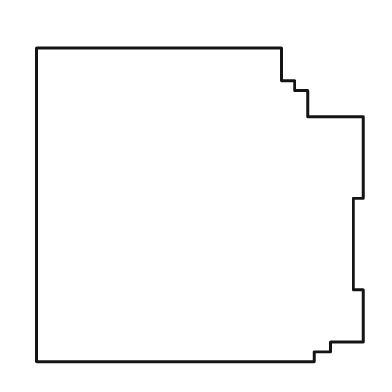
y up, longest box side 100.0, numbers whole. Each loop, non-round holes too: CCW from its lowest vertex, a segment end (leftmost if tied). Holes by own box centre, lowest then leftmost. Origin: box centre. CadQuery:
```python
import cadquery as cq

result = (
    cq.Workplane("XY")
    .moveTo(-50.0, -48.0)
    .lineTo(35.0, -48.0)
    .lineTo(35.0, -45.0)
    .lineTo(40.0, -45.0)
    .lineTo(40.0, -42.0)
    .lineTo(50.0, -42.0)
    .lineTo(50.0, -26.0)
    .lineTo(47.0, -26.0)
    .lineTo(47.0, 2.0)
    .lineTo(50.0, 2.0)
    .lineTo(50.0, 27.0)
    .lineTo(33.0, 27.0)
    .lineTo(33.0, 35.0)
    .lineTo(29.0, 35.0)
    .lineTo(29.0, 38.0)
    .lineTo(25.0, 38.0)
    .lineTo(25.0, 48.0)
    .lineTo(-50.0, 48.0)
    .close()
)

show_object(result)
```